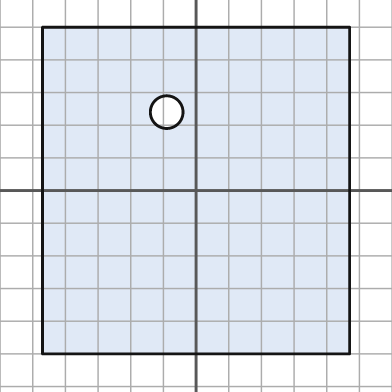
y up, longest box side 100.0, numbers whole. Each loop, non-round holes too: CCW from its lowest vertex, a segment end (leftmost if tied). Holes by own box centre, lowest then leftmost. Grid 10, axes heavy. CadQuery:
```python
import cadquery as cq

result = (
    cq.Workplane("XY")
    .moveTo(-47.0, -50.0)
    .lineTo(47.0, -50.0)
    .lineTo(47.0, 50.0)
    .lineTo(-47.0, 50.0)
    .close()
    .moveTo(-9.0, 24.0)
    .circle(5.0)
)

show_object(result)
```